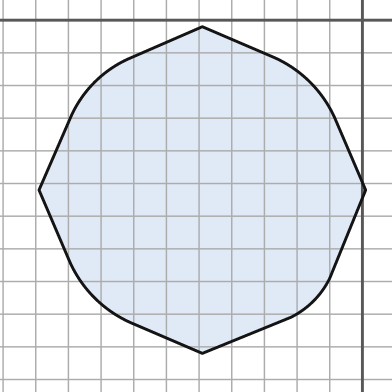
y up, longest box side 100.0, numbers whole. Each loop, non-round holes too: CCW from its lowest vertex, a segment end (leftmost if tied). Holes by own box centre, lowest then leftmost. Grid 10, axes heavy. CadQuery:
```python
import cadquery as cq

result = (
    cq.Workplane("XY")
    .moveTo(-49.0, -102.0)
    .lineTo(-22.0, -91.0)
    .threePointArc((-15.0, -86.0), (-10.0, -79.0))
    .lineTo(1.0, -52.0)
    .lineTo(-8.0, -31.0)
    .threePointArc((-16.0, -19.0), (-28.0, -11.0))
    .lineTo(-49.0, -2.0)
    .lineTo(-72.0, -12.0)
    .threePointArc((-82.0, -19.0), (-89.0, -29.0))
    .lineTo(-99.0, -52.0)
    .lineTo(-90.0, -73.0)
    .threePointArc((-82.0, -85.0), (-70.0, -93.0))
    .close()
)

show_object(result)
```